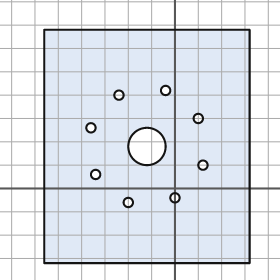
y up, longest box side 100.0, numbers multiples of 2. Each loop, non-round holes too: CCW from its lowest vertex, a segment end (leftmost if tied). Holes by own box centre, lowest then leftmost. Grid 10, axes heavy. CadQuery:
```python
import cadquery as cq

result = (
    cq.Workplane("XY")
    .moveTo(-56.0, -32.0)
    .lineTo(32.0, -32.0)
    .lineTo(32.0, 68.0)
    .lineTo(-56.0, 68.0)
    .close()
    .moveTo(-20.0, -6.0)
    .circle(2.0)
    .moveTo(0.0, -4.0)
    .circle(2.0)
    .moveTo(-34.0, 6.0)
    .circle(2.0)
    .moveTo(12.0, 10.0)
    .circle(2.0)
    .moveTo(-12.0, 18.0)
    .circle(8.0)
    .moveTo(-36.0, 26.0)
    .circle(2.0)
    .moveTo(10.0, 30.0)
    .circle(2.0)
    .moveTo(-24.0, 40.0)
    .circle(2.0)
    .moveTo(-4.0, 42.0)
    .circle(2.0)
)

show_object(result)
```